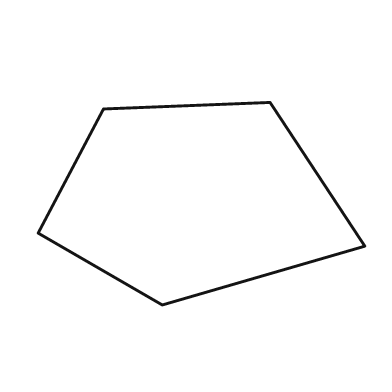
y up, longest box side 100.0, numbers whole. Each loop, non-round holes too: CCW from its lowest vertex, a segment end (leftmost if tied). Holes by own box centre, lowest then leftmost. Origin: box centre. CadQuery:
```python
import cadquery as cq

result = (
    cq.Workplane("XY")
    .moveTo(-12.0, -31.0)
    .lineTo(50.0, -13.0)
    .lineTo(21.0, 31.0)
    .lineTo(-30.0, 29.0)
    .lineTo(-50.0, -9.0)
    .close()
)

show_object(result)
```